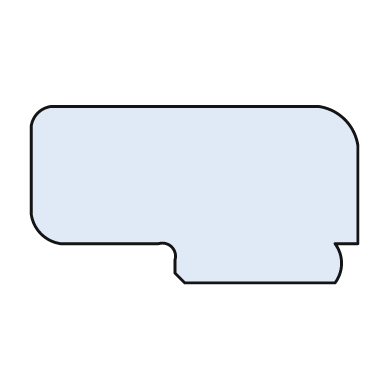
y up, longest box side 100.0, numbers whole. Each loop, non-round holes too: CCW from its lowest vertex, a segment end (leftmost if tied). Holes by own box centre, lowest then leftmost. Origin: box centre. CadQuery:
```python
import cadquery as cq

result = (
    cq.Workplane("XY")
    .moveTo(-3.0, -27.0)
    .lineTo(43.0, -27.0)
    .threePointArc((45.0, -21.0), (43.0, -15.0))
    .lineTo(50.0, -15.0)
    .lineTo(50.0, 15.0)
    .threePointArc((46.0, 23.0), (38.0, 27.0))
    .lineTo(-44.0, 27.0)
    .threePointArc((-48.0, 25.0), (-50.0, 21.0))
    .lineTo(-50.0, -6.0)
    .threePointArc((-47.0, -12.0), (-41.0, -15.0))
    .lineTo(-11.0, -15.0)
    .threePointArc((-7.0, -16.0), (-6.0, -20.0))
    .lineTo(-6.0, -24.0)
    .close()
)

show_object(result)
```